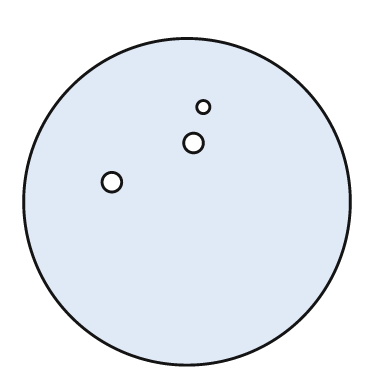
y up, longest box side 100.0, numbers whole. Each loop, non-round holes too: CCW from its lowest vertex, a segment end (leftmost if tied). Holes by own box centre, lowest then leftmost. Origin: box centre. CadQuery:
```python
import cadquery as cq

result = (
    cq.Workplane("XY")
    .moveTo(0.0, 0.0)
    .circle(50.0)
    .moveTo(-23.0, 6.0)
    .circle(3.0)
    .moveTo(2.0, 18.0)
    .circle(3.0)
    .moveTo(5.0, 29.0)
    .circle(2.0)
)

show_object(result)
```